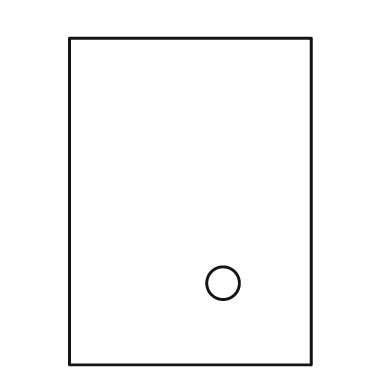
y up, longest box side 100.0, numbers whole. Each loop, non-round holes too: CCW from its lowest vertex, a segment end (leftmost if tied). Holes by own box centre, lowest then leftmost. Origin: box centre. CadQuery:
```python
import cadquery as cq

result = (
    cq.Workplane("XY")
    .moveTo(-37.0, -50.0)
    .lineTo(37.0, -50.0)
    .lineTo(37.0, 50.0)
    .lineTo(-37.0, 50.0)
    .close()
    .moveTo(10.0, -25.0)
    .circle(5.0)
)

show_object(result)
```